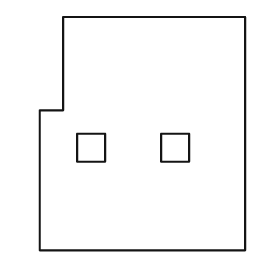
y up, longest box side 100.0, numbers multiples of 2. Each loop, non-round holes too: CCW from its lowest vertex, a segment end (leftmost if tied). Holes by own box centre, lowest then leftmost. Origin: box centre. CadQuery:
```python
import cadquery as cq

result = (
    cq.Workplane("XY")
    .moveTo(-44.0, -50.0)
    .lineTo(44.0, -50.0)
    .lineTo(44.0, 50.0)
    .lineTo(-34.0, 50.0)
    .lineTo(-34.0, 10.0)
    .lineTo(-44.0, 10.0)
    .close()
    .moveTo(-28.0, -12.0)
    .lineTo(-16.0, -12.0)
    .lineTo(-16.0, 0.0)
    .lineTo(-28.0, 0.0)
    .close()
    .moveTo(8.0, -12.0)
    .lineTo(20.0, -12.0)
    .lineTo(20.0, 0.0)
    .lineTo(8.0, 0.0)
    .close()
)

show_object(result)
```